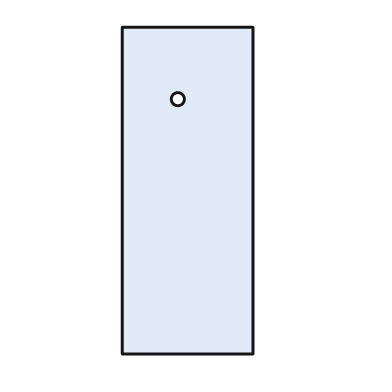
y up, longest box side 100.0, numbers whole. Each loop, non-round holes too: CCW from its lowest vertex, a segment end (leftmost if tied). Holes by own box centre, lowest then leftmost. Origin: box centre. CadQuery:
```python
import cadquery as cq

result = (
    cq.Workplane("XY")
    .moveTo(-20.0, -50.0)
    .lineTo(20.0, -50.0)
    .lineTo(20.0, 50.0)
    .lineTo(-20.0, 50.0)
    .close()
    .moveTo(-3.0, 28.0)
    .circle(2.0)
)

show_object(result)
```